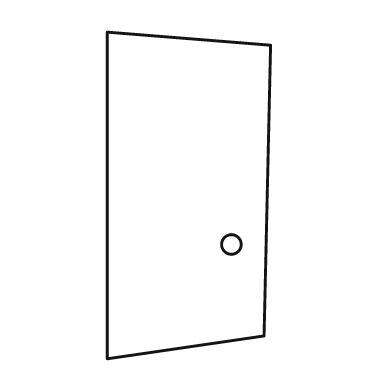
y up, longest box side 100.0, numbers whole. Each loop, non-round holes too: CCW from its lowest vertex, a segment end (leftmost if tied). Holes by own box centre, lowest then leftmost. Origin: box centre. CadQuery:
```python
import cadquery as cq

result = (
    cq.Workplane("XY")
    .moveTo(-25.0, -50.0)
    .lineTo(23.0, -43.0)
    .lineTo(25.0, 46.0)
    .lineTo(-25.0, 50.0)
    .close()
    .moveTo(13.0, -15.0)
    .circle(3.0)
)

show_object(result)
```